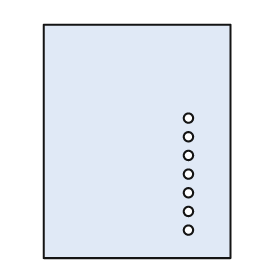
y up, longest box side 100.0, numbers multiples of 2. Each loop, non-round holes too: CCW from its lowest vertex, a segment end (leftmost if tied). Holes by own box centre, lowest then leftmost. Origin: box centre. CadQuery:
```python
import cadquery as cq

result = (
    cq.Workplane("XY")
    .moveTo(-40.0, -50.0)
    .lineTo(40.0, -50.0)
    .lineTo(40.0, 50.0)
    .lineTo(-40.0, 50.0)
    .close()
    .moveTo(22.0, -38.0)
    .circle(2.0)
    .moveTo(22.0, -30.0)
    .circle(2.0)
    .moveTo(22.0, -22.0)
    .circle(2.0)
    .moveTo(22.0, -14.0)
    .circle(2.0)
    .moveTo(22.0, -6.0)
    .circle(2.0)
    .moveTo(22.0, 2.0)
    .circle(2.0)
    .moveTo(22.0, 10.0)
    .circle(2.0)
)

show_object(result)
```